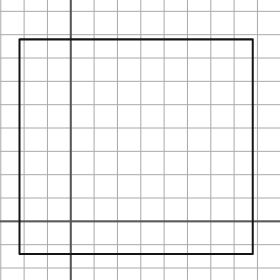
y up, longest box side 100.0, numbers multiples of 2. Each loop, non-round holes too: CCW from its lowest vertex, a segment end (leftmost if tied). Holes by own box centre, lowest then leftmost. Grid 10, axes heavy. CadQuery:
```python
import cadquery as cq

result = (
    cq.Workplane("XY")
    .moveTo(-22.0, -14.0)
    .lineTo(78.0, -14.0)
    .lineTo(78.0, 78.0)
    .lineTo(-22.0, 78.0)
    .close()
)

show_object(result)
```